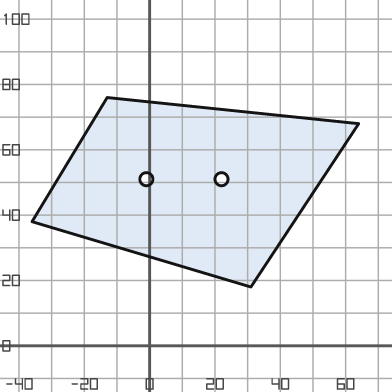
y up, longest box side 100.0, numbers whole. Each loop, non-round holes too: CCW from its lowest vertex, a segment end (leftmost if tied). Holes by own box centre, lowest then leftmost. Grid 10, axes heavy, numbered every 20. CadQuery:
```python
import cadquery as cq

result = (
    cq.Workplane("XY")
    .moveTo(31.0, 18.0)
    .lineTo(64.0, 68.0)
    .lineTo(-13.0, 76.0)
    .lineTo(-36.0, 38.0)
    .close()
    .moveTo(-1.0, 51.0)
    .circle(2.0)
    .moveTo(22.0, 51.0)
    .circle(2.0)
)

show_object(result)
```